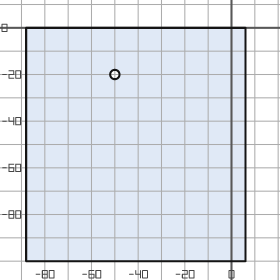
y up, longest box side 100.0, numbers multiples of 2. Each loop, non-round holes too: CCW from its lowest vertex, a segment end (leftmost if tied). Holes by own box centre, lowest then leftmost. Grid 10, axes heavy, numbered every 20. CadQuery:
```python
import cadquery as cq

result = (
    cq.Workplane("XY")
    .moveTo(-88.0, -100.0)
    .lineTo(6.0, -100.0)
    .lineTo(6.0, 0.0)
    .lineTo(-88.0, 0.0)
    .close()
    .moveTo(-50.0, -20.0)
    .circle(2.0)
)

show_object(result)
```